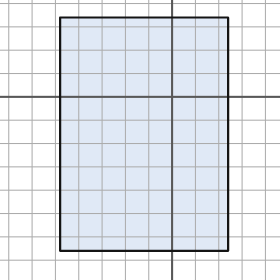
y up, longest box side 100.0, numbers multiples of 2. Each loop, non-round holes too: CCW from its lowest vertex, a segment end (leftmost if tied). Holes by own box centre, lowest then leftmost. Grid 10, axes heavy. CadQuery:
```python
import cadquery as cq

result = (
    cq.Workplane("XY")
    .moveTo(-48.0, -66.0)
    .lineTo(24.0, -66.0)
    .lineTo(24.0, 34.0)
    .lineTo(-48.0, 34.0)
    .close()
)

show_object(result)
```